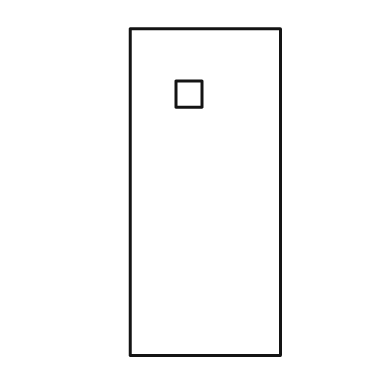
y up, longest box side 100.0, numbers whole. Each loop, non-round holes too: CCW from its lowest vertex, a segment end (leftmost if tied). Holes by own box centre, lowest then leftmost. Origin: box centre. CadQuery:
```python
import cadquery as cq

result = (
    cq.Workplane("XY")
    .moveTo(-23.0, -50.0)
    .lineTo(23.0, -50.0)
    .lineTo(23.0, 50.0)
    .lineTo(-23.0, 50.0)
    .close()
    .moveTo(-9.0, 26.0)
    .lineTo(-1.0, 26.0)
    .lineTo(-1.0, 34.0)
    .lineTo(-9.0, 34.0)
    .close()
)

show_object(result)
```